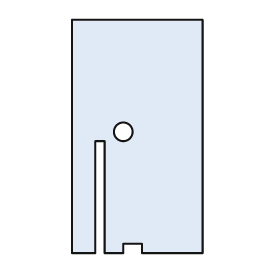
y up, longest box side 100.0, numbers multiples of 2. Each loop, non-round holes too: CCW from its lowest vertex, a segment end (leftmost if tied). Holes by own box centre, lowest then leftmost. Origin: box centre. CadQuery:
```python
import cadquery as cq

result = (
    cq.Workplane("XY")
    .moveTo(-28.0, -50.0)
    .lineTo(-18.0, -50.0)
    .lineTo(-18.0, -2.0)
    .lineTo(-14.0, -2.0)
    .lineTo(-14.0, -50.0)
    .lineTo(-6.0, -50.0)
    .lineTo(-6.0, -46.0)
    .lineTo(2.0, -46.0)
    .lineTo(2.0, -50.0)
    .lineTo(28.0, -50.0)
    .lineTo(28.0, 50.0)
    .lineTo(-28.0, 50.0)
    .close()
    .moveTo(-6.0, 2.0)
    .circle(4.0)
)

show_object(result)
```